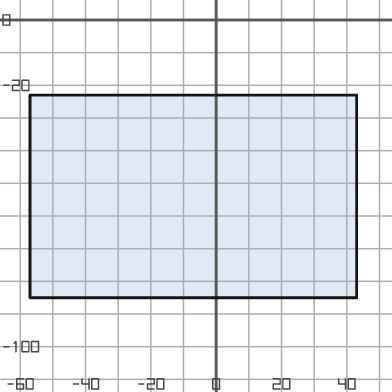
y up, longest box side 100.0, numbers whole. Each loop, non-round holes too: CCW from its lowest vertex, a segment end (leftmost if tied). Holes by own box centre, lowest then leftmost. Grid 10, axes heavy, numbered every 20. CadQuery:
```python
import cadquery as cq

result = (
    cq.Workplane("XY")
    .moveTo(-57.0, -85.0)
    .lineTo(43.0, -85.0)
    .lineTo(43.0, -23.0)
    .lineTo(-57.0, -23.0)
    .close()
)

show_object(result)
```